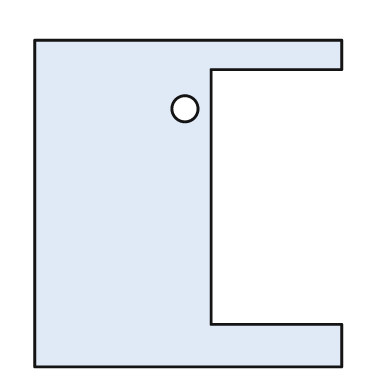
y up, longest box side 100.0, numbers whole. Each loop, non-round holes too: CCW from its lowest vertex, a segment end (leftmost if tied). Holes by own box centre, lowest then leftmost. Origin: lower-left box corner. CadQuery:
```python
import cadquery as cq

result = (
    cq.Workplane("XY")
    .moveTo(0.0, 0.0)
    .lineTo(94.0, 0.0)
    .lineTo(94.0, 13.0)
    .lineTo(54.0, 13.0)
    .lineTo(54.0, 91.0)
    .lineTo(94.0, 91.0)
    .lineTo(94.0, 100.0)
    .lineTo(0.0, 100.0)
    .close()
    .moveTo(46.0, 79.0)
    .circle(4.0)
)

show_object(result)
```